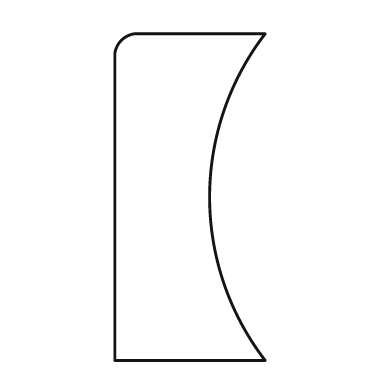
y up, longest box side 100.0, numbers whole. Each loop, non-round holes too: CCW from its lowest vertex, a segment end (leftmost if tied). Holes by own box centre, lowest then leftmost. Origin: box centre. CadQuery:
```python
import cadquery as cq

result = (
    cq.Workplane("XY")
    .moveTo(-23.0, -50.0)
    .lineTo(23.0, -50.0)
    .threePointArc((6.0, 0.0), (23.0, 50.0))
    .lineTo(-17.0, 50.0)
    .threePointArc((-21.0, 48.0), (-23.0, 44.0))
    .close()
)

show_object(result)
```